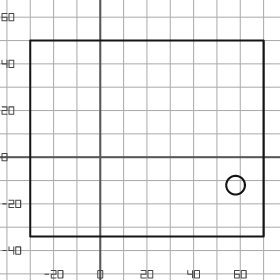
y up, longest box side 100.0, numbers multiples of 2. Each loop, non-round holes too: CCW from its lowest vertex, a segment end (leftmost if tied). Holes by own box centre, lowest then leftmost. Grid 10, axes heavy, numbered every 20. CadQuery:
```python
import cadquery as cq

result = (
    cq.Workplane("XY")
    .moveTo(-30.0, -34.0)
    .lineTo(70.0, -34.0)
    .lineTo(70.0, 50.0)
    .lineTo(-30.0, 50.0)
    .close()
    .moveTo(58.0, -12.0)
    .circle(4.0)
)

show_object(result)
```